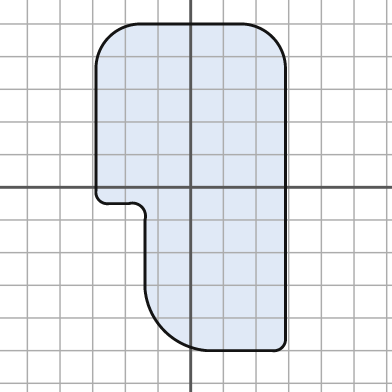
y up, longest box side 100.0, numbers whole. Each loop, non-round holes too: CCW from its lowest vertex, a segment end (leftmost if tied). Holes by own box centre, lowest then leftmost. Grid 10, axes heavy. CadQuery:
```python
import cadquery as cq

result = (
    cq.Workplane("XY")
    .moveTo(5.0, -50.0)
    .lineTo(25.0, -50.0)
    .threePointArc((28.0, -49.0), (29.0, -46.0))
    .lineTo(29.0, 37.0)
    .threePointArc((25.0, 46.0), (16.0, 50.0))
    .lineTo(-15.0, 50.0)
    .threePointArc((-25.0, 46.0), (-29.0, 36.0))
    .lineTo(-29.0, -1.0)
    .threePointArc((-28.0, -4.0), (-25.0, -5.0))
    .lineTo(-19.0, -5.0)
    .threePointArc((-15.0, -6.0), (-14.0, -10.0))
    .lineTo(-14.0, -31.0)
    .threePointArc((-8.0, -44.0), (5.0, -50.0))
    .close()
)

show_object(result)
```